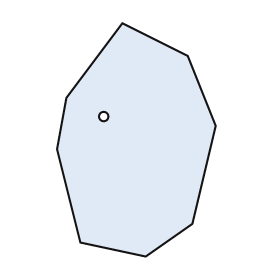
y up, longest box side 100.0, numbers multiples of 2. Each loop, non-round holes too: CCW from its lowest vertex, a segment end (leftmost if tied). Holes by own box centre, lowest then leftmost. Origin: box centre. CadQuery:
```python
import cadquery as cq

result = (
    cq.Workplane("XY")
    .moveTo(4.0, -50.0)
    .lineTo(24.0, -36.0)
    .lineTo(34.0, 6.0)
    .lineTo(22.0, 36.0)
    .lineTo(-6.0, 50.0)
    .lineTo(-30.0, 18.0)
    .lineTo(-34.0, -4.0)
    .lineTo(-24.0, -44.0)
    .close()
    .moveTo(-14.0, 10.0)
    .circle(2.0)
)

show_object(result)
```